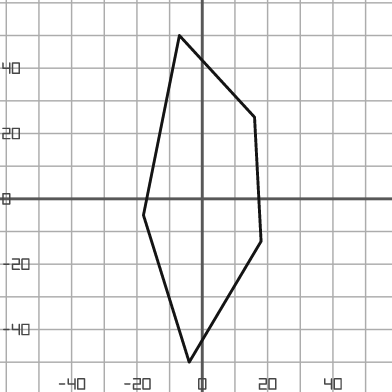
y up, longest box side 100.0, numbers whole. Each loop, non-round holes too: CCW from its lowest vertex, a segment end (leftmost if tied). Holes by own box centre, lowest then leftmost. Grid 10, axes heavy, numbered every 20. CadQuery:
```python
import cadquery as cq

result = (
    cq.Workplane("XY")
    .moveTo(-4.0, -50.0)
    .lineTo(18.0, -13.0)
    .lineTo(16.0, 25.0)
    .lineTo(-7.0, 50.0)
    .lineTo(-18.0, -5.0)
    .close()
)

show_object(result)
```